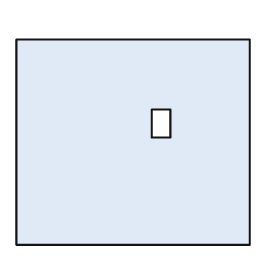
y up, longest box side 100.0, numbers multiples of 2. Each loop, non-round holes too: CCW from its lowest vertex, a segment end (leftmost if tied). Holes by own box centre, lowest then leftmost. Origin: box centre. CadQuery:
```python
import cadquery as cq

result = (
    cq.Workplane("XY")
    .moveTo(-50.0, -44.0)
    .lineTo(50.0, -44.0)
    .lineTo(50.0, 44.0)
    .lineTo(-50.0, 44.0)
    .close()
    .moveTo(8.0, 2.0)
    .lineTo(16.0, 2.0)
    .lineTo(16.0, 14.0)
    .lineTo(8.0, 14.0)
    .close()
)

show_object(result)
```